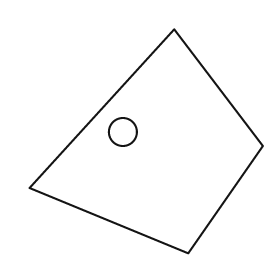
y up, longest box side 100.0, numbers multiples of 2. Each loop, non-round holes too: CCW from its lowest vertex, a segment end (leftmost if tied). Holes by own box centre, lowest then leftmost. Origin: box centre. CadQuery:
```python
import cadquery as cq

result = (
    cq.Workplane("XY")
    .moveTo(18.0, -48.0)
    .lineTo(50.0, -2.0)
    .lineTo(12.0, 48.0)
    .lineTo(-50.0, -20.0)
    .close()
    .moveTo(-10.0, 4.0)
    .circle(6.0)
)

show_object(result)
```